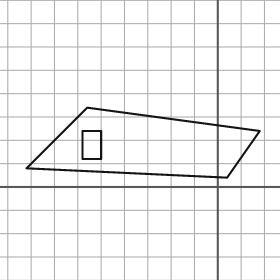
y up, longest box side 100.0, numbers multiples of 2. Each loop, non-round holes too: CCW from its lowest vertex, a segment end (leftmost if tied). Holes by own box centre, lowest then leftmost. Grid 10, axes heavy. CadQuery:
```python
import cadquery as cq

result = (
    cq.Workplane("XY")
    .moveTo(4.0, 4.0)
    .lineTo(18.0, 24.0)
    .lineTo(-56.0, 34.0)
    .lineTo(-82.0, 8.0)
    .close()
    .moveTo(-58.0, 12.0)
    .lineTo(-50.0, 12.0)
    .lineTo(-50.0, 24.0)
    .lineTo(-58.0, 24.0)
    .close()
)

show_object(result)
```